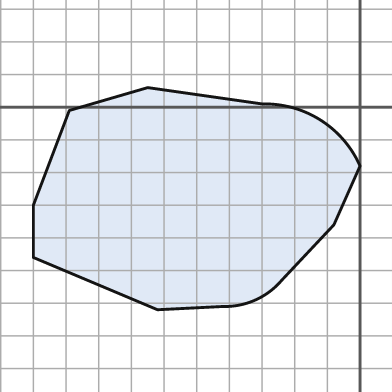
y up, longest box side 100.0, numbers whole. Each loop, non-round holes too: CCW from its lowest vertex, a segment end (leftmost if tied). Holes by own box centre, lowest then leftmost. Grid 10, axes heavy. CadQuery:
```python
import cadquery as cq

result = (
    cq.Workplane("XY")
    .moveTo(-62.0, -62.0)
    .lineTo(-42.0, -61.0)
    .threePointArc((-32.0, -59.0), (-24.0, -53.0))
    .lineTo(-8.0, -36.0)
    .lineTo(0.0, -18.0)
    .threePointArc((-12.0, -4.0), (-30.0, 1.0))
    .lineTo(-65.0, 6.0)
    .lineTo(-89.0, -1.0)
    .lineTo(-100.0, -30.0)
    .lineTo(-100.0, -46.0)
    .close()
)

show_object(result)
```